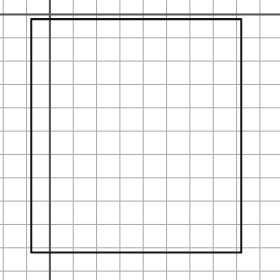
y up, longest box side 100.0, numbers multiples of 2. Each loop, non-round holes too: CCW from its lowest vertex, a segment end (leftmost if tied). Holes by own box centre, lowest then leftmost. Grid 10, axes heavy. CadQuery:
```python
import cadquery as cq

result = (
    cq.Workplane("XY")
    .moveTo(-8.0, -102.0)
    .lineTo(82.0, -102.0)
    .lineTo(82.0, -2.0)
    .lineTo(-8.0, -2.0)
    .close()
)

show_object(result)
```